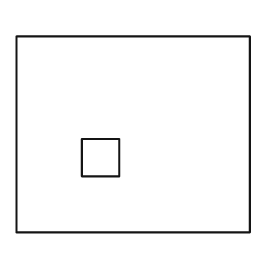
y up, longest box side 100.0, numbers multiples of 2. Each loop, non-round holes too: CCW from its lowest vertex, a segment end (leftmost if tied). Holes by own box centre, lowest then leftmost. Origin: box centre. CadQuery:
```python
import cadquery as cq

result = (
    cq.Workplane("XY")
    .moveTo(-50.0, -42.0)
    .lineTo(50.0, -42.0)
    .lineTo(50.0, 42.0)
    .lineTo(-50.0, 42.0)
    .close()
    .moveTo(-22.0, -18.0)
    .lineTo(-6.0, -18.0)
    .lineTo(-6.0, -2.0)
    .lineTo(-22.0, -2.0)
    .close()
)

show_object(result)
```